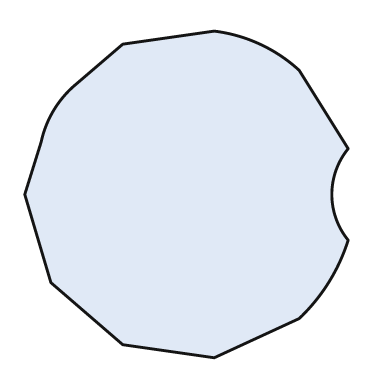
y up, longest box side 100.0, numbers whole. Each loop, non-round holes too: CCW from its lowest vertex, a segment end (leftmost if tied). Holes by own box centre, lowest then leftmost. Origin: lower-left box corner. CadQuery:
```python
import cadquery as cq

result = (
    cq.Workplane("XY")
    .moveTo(58.0, 0.0)
    .lineTo(84.0, 12.0)
    .threePointArc((93.0, 23.0), (99.0, 36.0))
    .threePointArc((94.0, 50.0), (99.0, 64.0))
    .lineTo(84.0, 88.0)
    .threePointArc((72.0, 96.0), (58.0, 100.0))
    .lineTo(30.0, 96.0)
    .lineTo(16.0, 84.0)
    .threePointArc((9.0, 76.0), (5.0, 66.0))
    .lineTo(0.0, 50.0)
    .lineTo(8.0, 23.0)
    .lineTo(30.0, 4.0)
    .close()
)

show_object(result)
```